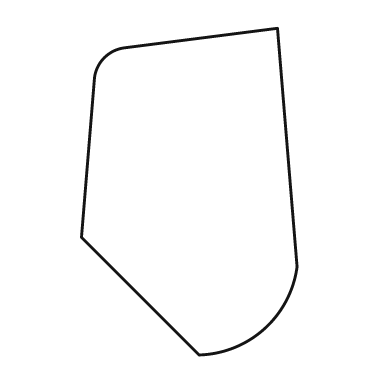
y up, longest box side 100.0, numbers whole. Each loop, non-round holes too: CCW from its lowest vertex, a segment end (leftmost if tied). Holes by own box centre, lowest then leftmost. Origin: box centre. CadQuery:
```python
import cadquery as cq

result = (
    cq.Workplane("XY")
    .moveTo(3.0, -50.0)
    .threePointArc((23.0, -42.0), (33.0, -23.0))
    .lineTo(27.0, 50.0)
    .lineTo(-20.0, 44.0)
    .threePointArc((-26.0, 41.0), (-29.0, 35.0))
    .lineTo(-33.0, -14.0)
    .close()
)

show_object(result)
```